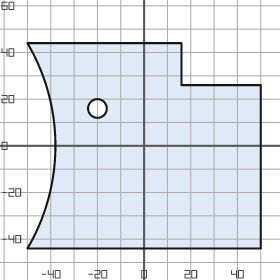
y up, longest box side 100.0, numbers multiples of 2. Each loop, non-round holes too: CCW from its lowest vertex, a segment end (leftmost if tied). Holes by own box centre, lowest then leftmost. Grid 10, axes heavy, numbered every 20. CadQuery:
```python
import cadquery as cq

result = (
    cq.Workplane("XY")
    .moveTo(-50.0, -44.0)
    .lineTo(50.0, -44.0)
    .lineTo(50.0, 26.0)
    .lineTo(16.0, 26.0)
    .lineTo(16.0, 44.0)
    .lineTo(-50.0, 44.0)
    .threePointArc((-38.0, 0.0), (-50.0, -44.0))
    .close()
    .moveTo(-20.0, 16.0)
    .circle(4.0)
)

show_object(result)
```